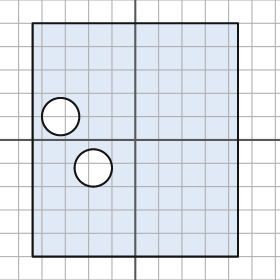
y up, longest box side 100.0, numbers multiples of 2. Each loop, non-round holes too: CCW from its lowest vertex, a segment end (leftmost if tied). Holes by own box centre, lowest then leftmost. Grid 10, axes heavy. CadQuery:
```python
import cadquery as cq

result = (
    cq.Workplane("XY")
    .moveTo(-44.0, -50.0)
    .lineTo(44.0, -50.0)
    .lineTo(44.0, 50.0)
    .lineTo(-44.0, 50.0)
    .close()
    .moveTo(-18.0, -12.0)
    .circle(8.0)
    .moveTo(-32.0, 10.0)
    .circle(8.0)
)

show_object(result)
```